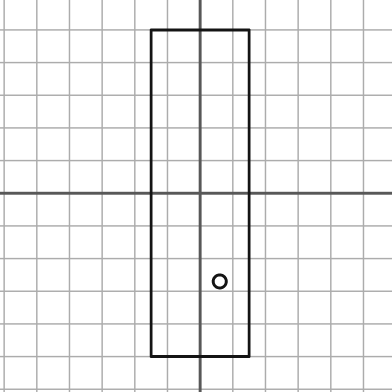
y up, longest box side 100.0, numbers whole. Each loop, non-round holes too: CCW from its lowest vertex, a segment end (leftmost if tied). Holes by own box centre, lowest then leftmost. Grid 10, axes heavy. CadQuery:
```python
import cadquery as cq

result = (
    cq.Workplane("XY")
    .moveTo(-15.0, -50.0)
    .lineTo(15.0, -50.0)
    .lineTo(15.0, 50.0)
    .lineTo(-15.0, 50.0)
    .close()
    .moveTo(6.0, -27.0)
    .circle(2.0)
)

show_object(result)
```